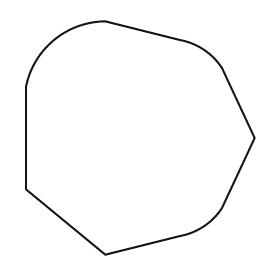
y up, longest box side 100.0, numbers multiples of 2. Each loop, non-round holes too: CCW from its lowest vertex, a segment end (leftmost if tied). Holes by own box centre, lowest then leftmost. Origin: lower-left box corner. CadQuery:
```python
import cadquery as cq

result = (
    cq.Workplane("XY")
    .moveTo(34.0, 0.0)
    .lineTo(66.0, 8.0)
    .threePointArc((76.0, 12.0), (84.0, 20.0))
    .lineTo(98.0, 50.0)
    .lineTo(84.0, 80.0)
    .threePointArc((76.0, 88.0), (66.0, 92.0))
    .lineTo(34.0, 100.0)
    .threePointArc((12.0, 92.0), (0.0, 72.0))
    .lineTo(0.0, 28.0)
    .close()
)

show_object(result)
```